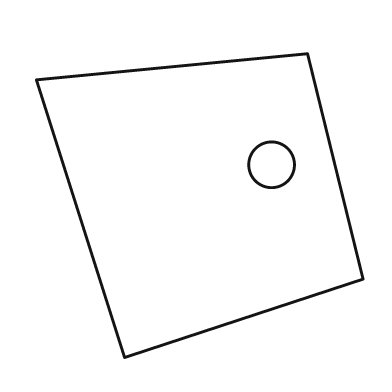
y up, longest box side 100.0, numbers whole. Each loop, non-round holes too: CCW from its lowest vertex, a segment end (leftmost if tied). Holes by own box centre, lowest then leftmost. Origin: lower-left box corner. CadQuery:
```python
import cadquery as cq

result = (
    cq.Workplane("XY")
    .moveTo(27.0, 0.0)
    .lineTo(100.0, 24.0)
    .lineTo(83.0, 93.0)
    .lineTo(0.0, 85.0)
    .close()
    .moveTo(72.0, 59.0)
    .circle(7.0)
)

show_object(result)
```